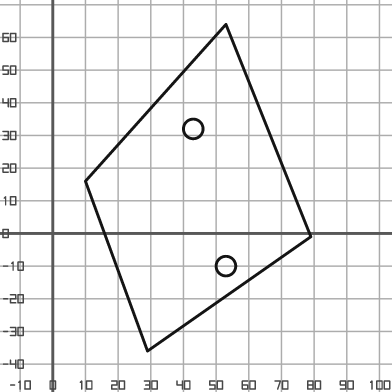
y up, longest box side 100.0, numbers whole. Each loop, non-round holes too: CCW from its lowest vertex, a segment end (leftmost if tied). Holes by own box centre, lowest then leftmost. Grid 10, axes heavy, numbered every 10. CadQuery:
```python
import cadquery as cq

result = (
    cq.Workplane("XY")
    .moveTo(29.0, -36.0)
    .lineTo(79.0, -1.0)
    .lineTo(53.0, 64.0)
    .lineTo(10.0, 16.0)
    .close()
    .moveTo(53.0, -10.0)
    .circle(3.0)
    .moveTo(43.0, 32.0)
    .circle(3.0)
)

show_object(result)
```